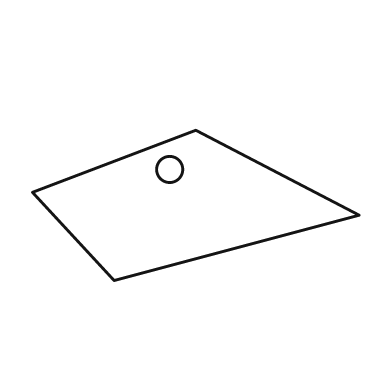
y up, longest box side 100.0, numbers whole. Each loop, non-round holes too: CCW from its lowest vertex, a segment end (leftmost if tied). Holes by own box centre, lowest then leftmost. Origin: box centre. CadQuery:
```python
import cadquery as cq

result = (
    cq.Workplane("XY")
    .moveTo(-25.0, -23.0)
    .lineTo(50.0, -3.0)
    .lineTo(0.0, 23.0)
    .lineTo(-50.0, 4.0)
    .close()
    .moveTo(-8.0, 11.0)
    .circle(4.0)
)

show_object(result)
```